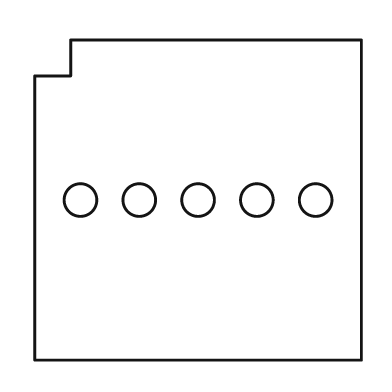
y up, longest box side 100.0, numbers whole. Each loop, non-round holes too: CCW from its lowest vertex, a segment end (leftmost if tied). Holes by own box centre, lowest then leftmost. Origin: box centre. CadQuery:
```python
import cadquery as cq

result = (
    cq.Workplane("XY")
    .moveTo(-50.0, -49.0)
    .lineTo(50.0, -49.0)
    .lineTo(50.0, 49.0)
    .lineTo(-39.0, 49.0)
    .lineTo(-39.0, 38.0)
    .lineTo(-50.0, 38.0)
    .close()
    .moveTo(-36.0, 0.0)
    .circle(5.0)
    .moveTo(-18.0, 0.0)
    .circle(5.0)
    .moveTo(0.0, 0.0)
    .circle(5.0)
    .moveTo(18.0, 0.0)
    .circle(5.0)
    .moveTo(36.0, 0.0)
    .circle(5.0)
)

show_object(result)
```